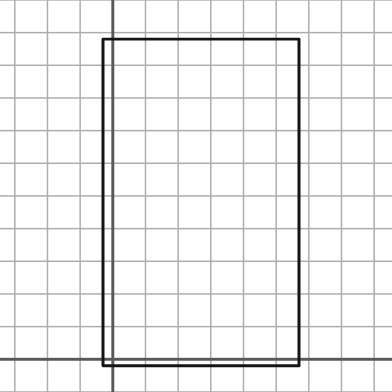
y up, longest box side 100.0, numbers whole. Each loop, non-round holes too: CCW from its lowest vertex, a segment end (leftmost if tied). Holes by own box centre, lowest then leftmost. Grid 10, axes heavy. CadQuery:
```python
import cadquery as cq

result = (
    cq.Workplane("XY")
    .moveTo(-3.0, -2.0)
    .lineTo(57.0, -2.0)
    .lineTo(57.0, 98.0)
    .lineTo(-3.0, 98.0)
    .close()
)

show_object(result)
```